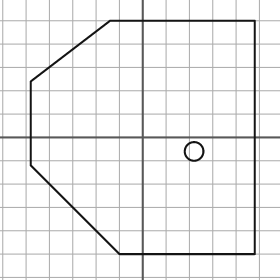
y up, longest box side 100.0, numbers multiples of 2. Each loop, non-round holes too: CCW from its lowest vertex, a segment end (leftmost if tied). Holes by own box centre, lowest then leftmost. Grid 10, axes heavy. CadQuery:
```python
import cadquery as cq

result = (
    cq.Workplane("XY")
    .moveTo(-10.0, -50.0)
    .lineTo(48.0, -50.0)
    .lineTo(48.0, 50.0)
    .lineTo(-14.0, 50.0)
    .lineTo(-48.0, 24.0)
    .lineTo(-48.0, -12.0)
    .close()
    .moveTo(22.0, -6.0)
    .circle(4.0)
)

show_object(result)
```